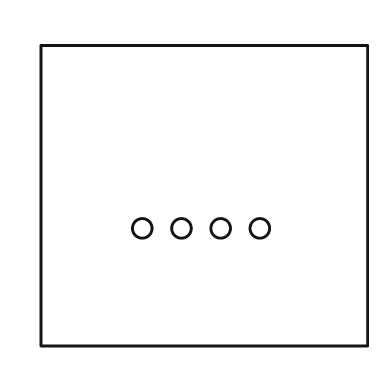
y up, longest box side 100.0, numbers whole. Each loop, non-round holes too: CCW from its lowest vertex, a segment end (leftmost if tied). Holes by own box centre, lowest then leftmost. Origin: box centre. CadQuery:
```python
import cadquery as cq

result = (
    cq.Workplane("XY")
    .moveTo(-50.0, -46.0)
    .lineTo(50.0, -46.0)
    .lineTo(50.0, 46.0)
    .lineTo(-50.0, 46.0)
    .close()
    .moveTo(-19.0, -10.0)
    .circle(3.0)
    .moveTo(-7.0, -10.0)
    .circle(3.0)
    .moveTo(5.0, -10.0)
    .circle(3.0)
    .moveTo(17.0, -10.0)
    .circle(3.0)
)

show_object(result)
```